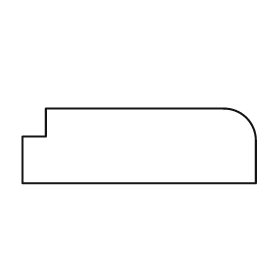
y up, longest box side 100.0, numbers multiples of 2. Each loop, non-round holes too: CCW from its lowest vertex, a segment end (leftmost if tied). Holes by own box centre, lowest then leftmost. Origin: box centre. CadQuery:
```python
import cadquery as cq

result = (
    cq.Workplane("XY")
    .moveTo(-50.0, -16.0)
    .lineTo(50.0, -16.0)
    .lineTo(50.0, 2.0)
    .threePointArc((46.0, 12.0), (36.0, 16.0))
    .lineTo(-40.0, 16.0)
    .lineTo(-40.0, 4.0)
    .lineTo(-50.0, 4.0)
    .close()
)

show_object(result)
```